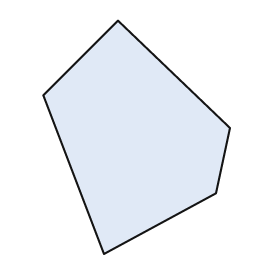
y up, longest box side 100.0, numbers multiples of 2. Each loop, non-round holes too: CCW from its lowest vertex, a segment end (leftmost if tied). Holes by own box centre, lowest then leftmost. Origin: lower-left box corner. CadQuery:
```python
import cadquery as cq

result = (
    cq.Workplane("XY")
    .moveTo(26.0, 0.0)
    .lineTo(74.0, 26.0)
    .lineTo(80.0, 54.0)
    .lineTo(32.0, 100.0)
    .lineTo(0.0, 68.0)
    .close()
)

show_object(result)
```